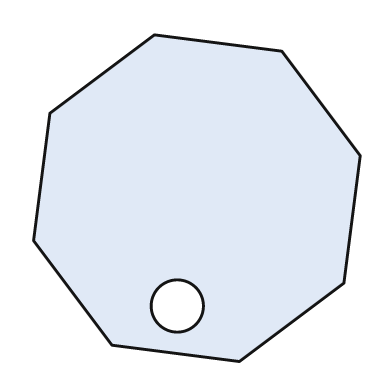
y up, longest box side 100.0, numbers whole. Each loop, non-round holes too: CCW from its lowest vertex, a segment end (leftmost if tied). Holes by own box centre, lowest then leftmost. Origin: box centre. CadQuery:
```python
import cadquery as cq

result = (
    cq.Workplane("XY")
    .moveTo(13.0, -50.0)
    .lineTo(45.0, -26.0)
    .lineTo(50.0, 13.0)
    .lineTo(26.0, 45.0)
    .lineTo(-13.0, 50.0)
    .lineTo(-45.0, 26.0)
    .lineTo(-50.0, -13.0)
    .lineTo(-26.0, -45.0)
    .close()
    .moveTo(-6.0, -33.0)
    .circle(8.0)
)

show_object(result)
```